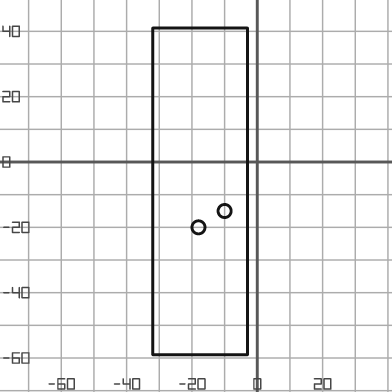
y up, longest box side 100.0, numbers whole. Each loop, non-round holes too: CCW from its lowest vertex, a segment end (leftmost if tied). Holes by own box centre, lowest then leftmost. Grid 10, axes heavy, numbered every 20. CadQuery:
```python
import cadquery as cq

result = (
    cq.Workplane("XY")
    .moveTo(-32.0, -59.0)
    .lineTo(-3.0, -59.0)
    .lineTo(-3.0, 41.0)
    .lineTo(-32.0, 41.0)
    .close()
    .moveTo(-18.0, -20.0)
    .circle(2.0)
    .moveTo(-10.0, -15.0)
    .circle(2.0)
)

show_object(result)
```